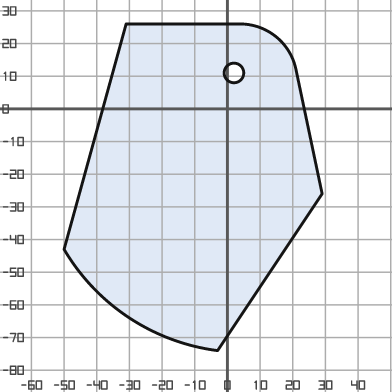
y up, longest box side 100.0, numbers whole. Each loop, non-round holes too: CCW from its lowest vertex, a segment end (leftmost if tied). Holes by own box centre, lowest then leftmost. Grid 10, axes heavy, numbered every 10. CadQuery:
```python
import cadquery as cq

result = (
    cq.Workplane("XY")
    .moveTo(-3.0, -74.0)
    .lineTo(29.0, -26.0)
    .lineTo(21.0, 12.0)
    .threePointArc((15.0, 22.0), (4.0, 26.0))
    .lineTo(-31.0, 26.0)
    .lineTo(-50.0, -43.0)
    .threePointArc((-30.0, -64.0), (-3.0, -74.0))
    .close()
    .moveTo(2.0, 11.0)
    .circle(3.0)
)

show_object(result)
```